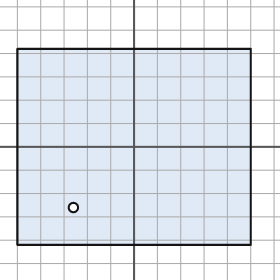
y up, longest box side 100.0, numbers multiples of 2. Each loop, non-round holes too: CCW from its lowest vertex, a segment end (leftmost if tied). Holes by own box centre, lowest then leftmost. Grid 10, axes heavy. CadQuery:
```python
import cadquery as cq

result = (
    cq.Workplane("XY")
    .moveTo(-50.0, -42.0)
    .lineTo(50.0, -42.0)
    .lineTo(50.0, 42.0)
    .lineTo(-50.0, 42.0)
    .close()
    .moveTo(-26.0, -26.0)
    .circle(2.0)
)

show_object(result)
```